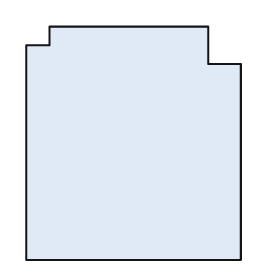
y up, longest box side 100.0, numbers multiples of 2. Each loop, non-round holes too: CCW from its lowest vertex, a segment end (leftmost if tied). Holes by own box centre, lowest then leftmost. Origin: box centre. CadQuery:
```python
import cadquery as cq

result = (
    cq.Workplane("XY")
    .moveTo(-46.0, -50.0)
    .lineTo(46.0, -50.0)
    .lineTo(46.0, 34.0)
    .lineTo(32.0, 34.0)
    .lineTo(32.0, 50.0)
    .lineTo(-36.0, 50.0)
    .lineTo(-36.0, 42.0)
    .lineTo(-46.0, 42.0)
    .close()
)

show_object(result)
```